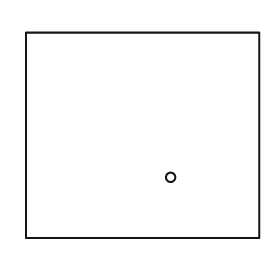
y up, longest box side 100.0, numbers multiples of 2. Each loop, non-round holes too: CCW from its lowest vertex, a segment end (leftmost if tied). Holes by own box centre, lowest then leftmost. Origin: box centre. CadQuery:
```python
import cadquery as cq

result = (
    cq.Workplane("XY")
    .moveTo(-50.0, -44.0)
    .lineTo(50.0, -44.0)
    .lineTo(50.0, 44.0)
    .lineTo(-50.0, 44.0)
    .close()
    .moveTo(12.0, -18.0)
    .circle(2.0)
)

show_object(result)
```